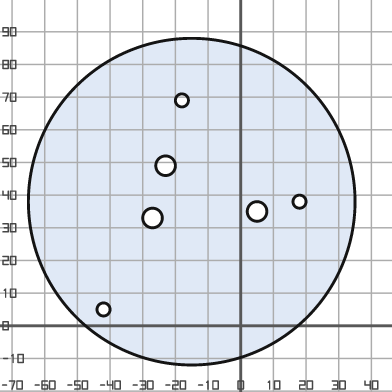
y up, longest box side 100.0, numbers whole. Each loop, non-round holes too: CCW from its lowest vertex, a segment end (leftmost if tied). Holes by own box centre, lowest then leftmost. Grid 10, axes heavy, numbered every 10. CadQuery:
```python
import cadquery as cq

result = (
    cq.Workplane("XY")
    .moveTo(-15.0, 38.0)
    .circle(50.0)
    .moveTo(-42.0, 5.0)
    .circle(2.0)
    .moveTo(-27.0, 33.0)
    .circle(3.0)
    .moveTo(5.0, 35.0)
    .circle(3.0)
    .moveTo(18.0, 38.0)
    .circle(2.0)
    .moveTo(-23.0, 49.0)
    .circle(3.0)
    .moveTo(-18.0, 69.0)
    .circle(2.0)
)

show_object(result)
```